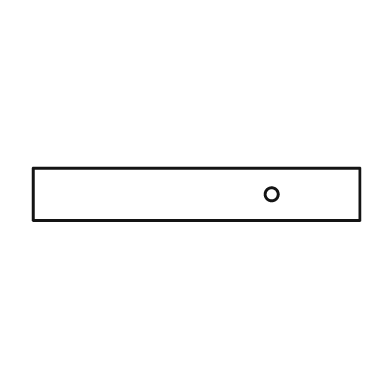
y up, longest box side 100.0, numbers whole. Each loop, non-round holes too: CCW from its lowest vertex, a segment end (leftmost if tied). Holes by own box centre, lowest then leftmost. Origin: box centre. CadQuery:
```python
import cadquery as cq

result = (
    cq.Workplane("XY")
    .moveTo(-50.0, -8.0)
    .lineTo(50.0, -8.0)
    .lineTo(50.0, 8.0)
    .lineTo(-50.0, 8.0)
    .close()
    .moveTo(23.0, 0.0)
    .circle(2.0)
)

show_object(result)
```